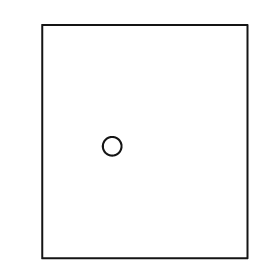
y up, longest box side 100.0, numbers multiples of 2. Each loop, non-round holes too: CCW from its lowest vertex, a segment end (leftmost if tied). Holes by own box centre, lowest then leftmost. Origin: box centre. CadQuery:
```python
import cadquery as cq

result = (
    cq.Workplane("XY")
    .moveTo(-44.0, -50.0)
    .lineTo(44.0, -50.0)
    .lineTo(44.0, 50.0)
    .lineTo(-44.0, 50.0)
    .close()
    .moveTo(-14.0, -2.0)
    .circle(4.0)
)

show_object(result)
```